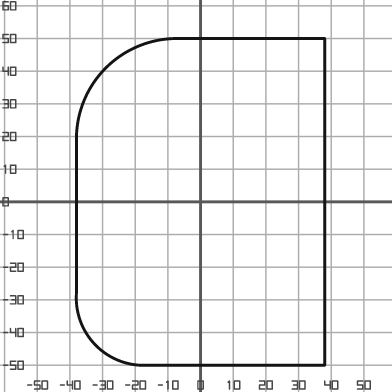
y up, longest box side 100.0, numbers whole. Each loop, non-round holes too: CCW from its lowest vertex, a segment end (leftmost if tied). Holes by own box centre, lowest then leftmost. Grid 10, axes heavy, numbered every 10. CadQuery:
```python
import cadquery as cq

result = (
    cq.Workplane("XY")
    .moveTo(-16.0, -50.0)
    .lineTo(38.0, -50.0)
    .lineTo(38.0, 50.0)
    .lineTo(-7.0, 50.0)
    .threePointArc((-29.0, 41.0), (-38.0, 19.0))
    .lineTo(-38.0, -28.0)
    .threePointArc((-32.0, -44.0), (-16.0, -50.0))
    .close()
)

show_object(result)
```